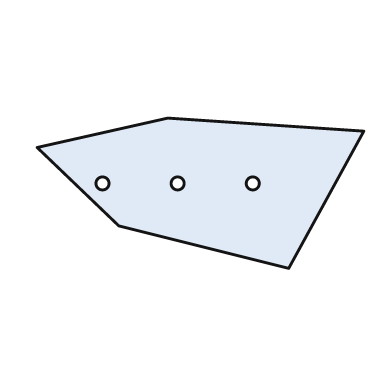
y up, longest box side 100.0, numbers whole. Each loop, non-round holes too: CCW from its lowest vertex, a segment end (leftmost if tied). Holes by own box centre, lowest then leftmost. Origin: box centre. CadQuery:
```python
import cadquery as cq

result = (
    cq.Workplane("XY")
    .moveTo(27.0, -23.0)
    .lineTo(50.0, 19.0)
    .lineTo(-10.0, 23.0)
    .lineTo(-50.0, 14.0)
    .lineTo(-25.0, -10.0)
    .close()
    .moveTo(-30.0, 3.0)
    .circle(2.0)
    .moveTo(-7.0, 3.0)
    .circle(2.0)
    .moveTo(16.0, 3.0)
    .circle(2.0)
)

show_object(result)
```